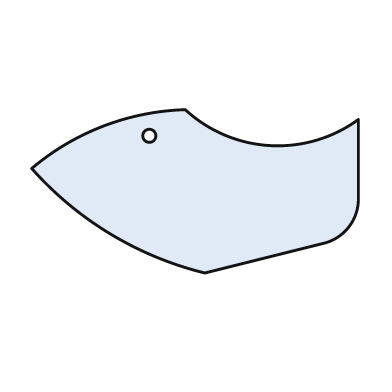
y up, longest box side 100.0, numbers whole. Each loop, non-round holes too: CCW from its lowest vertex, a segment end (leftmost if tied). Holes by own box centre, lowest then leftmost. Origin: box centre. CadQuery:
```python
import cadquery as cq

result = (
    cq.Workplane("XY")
    .moveTo(3.0, -25.0)
    .lineTo(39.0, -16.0)
    .threePointArc((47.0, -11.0), (50.0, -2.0))
    .lineTo(50.0, 22.0)
    .threePointArc((23.0, 14.0), (-3.0, 25.0))
    .threePointArc((-28.0, 20.0), (-50.0, 7.0))
    .threePointArc((-26.0, -13.0), (3.0, -25.0))
    .close()
    .moveTo(-14.0, 17.0)
    .circle(2.0)
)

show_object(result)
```